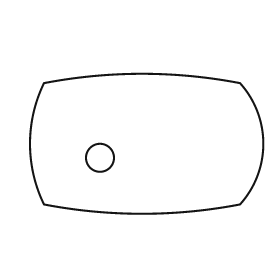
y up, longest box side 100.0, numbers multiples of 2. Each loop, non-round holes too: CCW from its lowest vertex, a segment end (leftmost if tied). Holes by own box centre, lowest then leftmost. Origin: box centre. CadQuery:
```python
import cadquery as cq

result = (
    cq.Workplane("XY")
    .moveTo(-44.0, -26.0)
    .threePointArc((-2.0, -30.0), (40.0, -26.0))
    .threePointArc((50.0, 0.0), (40.0, 26.0))
    .threePointArc((-2.0, 30.0), (-44.0, 26.0))
    .threePointArc((-50.0, 0.0), (-44.0, -26.0))
    .close()
    .moveTo(-20.0, -6.0)
    .circle(6.0)
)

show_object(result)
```